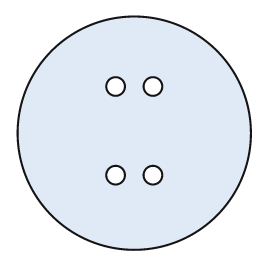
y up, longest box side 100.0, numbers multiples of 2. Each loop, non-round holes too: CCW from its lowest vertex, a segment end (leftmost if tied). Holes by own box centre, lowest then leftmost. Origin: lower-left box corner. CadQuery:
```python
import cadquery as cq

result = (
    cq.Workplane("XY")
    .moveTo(50.0, 50.0)
    .circle(50.0)
    .moveTo(42.0, 32.0)
    .circle(4.0)
    .moveTo(58.0, 32.0)
    .circle(4.0)
    .moveTo(42.0, 70.0)
    .circle(4.0)
    .moveTo(58.0, 70.0)
    .circle(4.0)
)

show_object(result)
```